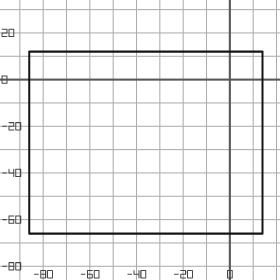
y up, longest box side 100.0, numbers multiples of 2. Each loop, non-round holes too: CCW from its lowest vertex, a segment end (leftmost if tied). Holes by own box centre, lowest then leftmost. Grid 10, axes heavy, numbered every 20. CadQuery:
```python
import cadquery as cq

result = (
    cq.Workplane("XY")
    .moveTo(-86.0, -66.0)
    .lineTo(14.0, -66.0)
    .lineTo(14.0, 12.0)
    .lineTo(-86.0, 12.0)
    .close()
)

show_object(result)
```